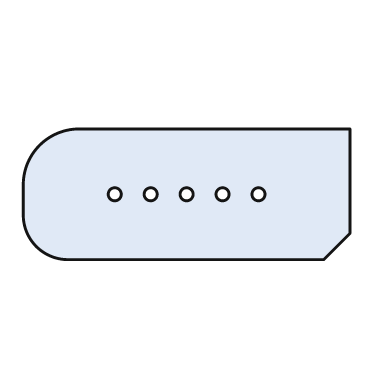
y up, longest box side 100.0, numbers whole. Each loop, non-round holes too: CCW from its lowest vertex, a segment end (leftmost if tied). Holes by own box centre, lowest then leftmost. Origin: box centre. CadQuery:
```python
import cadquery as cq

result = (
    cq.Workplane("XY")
    .moveTo(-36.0, -20.0)
    .lineTo(42.0, -20.0)
    .lineTo(50.0, -12.0)
    .lineTo(50.0, 20.0)
    .lineTo(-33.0, 20.0)
    .threePointArc((-45.0, 15.0), (-50.0, 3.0))
    .lineTo(-50.0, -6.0)
    .threePointArc((-46.0, -16.0), (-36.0, -20.0))
    .close()
    .moveTo(-22.0, 0.0)
    .circle(2.0)
    .moveTo(-11.0, 0.0)
    .circle(2.0)
    .moveTo(0.0, 0.0)
    .circle(2.0)
    .moveTo(11.0, 0.0)
    .circle(2.0)
    .moveTo(22.0, 0.0)
    .circle(2.0)
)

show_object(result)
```